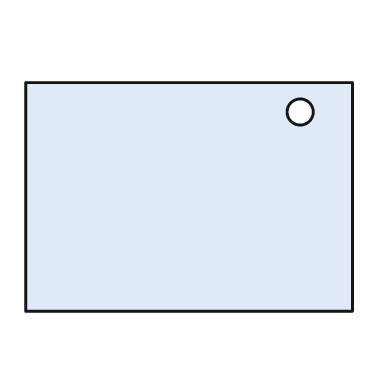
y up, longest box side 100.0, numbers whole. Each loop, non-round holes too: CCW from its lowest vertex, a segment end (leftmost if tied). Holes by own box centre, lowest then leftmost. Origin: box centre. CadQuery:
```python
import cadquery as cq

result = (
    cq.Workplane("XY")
    .moveTo(-50.0, -35.0)
    .lineTo(50.0, -35.0)
    .lineTo(50.0, 35.0)
    .lineTo(-50.0, 35.0)
    .close()
    .moveTo(34.0, 26.0)
    .circle(4.0)
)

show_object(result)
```